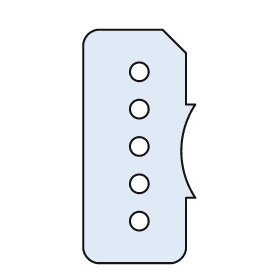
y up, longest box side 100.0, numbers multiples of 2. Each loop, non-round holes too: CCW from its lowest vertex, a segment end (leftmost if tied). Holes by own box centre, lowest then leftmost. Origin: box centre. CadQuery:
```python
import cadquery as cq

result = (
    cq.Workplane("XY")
    .moveTo(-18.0, -50.0)
    .lineTo(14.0, -50.0)
    .threePointArc((18.0, -48.0), (20.0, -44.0))
    .lineTo(20.0, -22.0)
    .lineTo(24.0, -22.0)
    .threePointArc((18.0, -2.0), (24.0, 18.0))
    .lineTo(20.0, 18.0)
    .lineTo(20.0, 40.0)
    .lineTo(10.0, 50.0)
    .lineTo(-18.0, 50.0)
    .threePointArc((-22.0, 48.0), (-24.0, 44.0))
    .lineTo(-24.0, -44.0)
    .threePointArc((-22.0, -48.0), (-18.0, -50.0))
    .close()
    .moveTo(0.0, -32.0)
    .circle(4.0)
    .moveTo(0.0, -16.0)
    .circle(4.0)
    .moveTo(0.0, 0.0)
    .circle(4.0)
    .moveTo(0.0, 16.0)
    .circle(4.0)
    .moveTo(0.0, 32.0)
    .circle(4.0)
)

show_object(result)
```